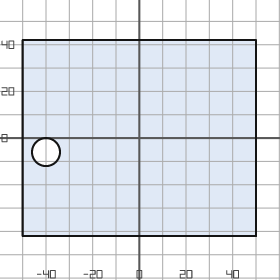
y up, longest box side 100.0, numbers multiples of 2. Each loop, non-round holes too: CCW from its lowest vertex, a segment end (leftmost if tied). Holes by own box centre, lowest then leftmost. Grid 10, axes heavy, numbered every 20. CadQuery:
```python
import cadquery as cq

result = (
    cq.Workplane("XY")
    .moveTo(-50.0, -42.0)
    .lineTo(50.0, -42.0)
    .lineTo(50.0, 42.0)
    .lineTo(-50.0, 42.0)
    .close()
    .moveTo(-40.0, -6.0)
    .circle(6.0)
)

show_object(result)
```